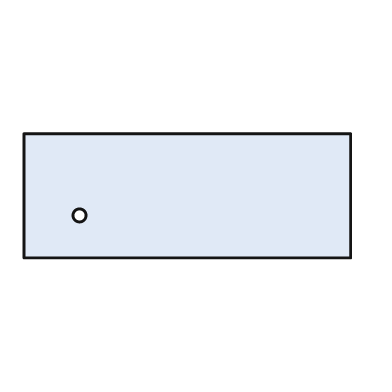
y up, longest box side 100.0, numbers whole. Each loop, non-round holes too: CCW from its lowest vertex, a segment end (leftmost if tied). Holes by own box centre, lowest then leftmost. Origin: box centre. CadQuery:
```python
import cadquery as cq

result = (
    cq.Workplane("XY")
    .moveTo(-50.0, -19.0)
    .lineTo(50.0, -19.0)
    .lineTo(50.0, 19.0)
    .lineTo(-50.0, 19.0)
    .close()
    .moveTo(-33.0, -6.0)
    .circle(2.0)
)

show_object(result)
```